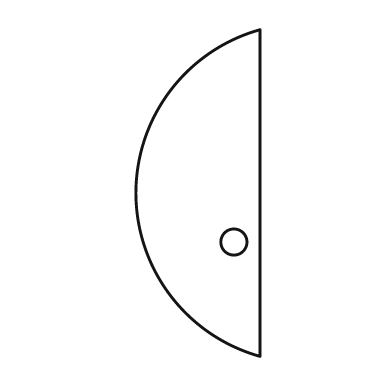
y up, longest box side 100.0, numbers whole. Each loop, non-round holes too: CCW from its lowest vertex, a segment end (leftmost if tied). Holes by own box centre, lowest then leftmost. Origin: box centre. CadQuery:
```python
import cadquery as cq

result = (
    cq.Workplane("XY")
    .moveTo(19.0, -50.0)
    .lineTo(19.0, 50.0)
    .threePointArc((-19.0, 0.0), (19.0, -50.0))
    .close()
    .moveTo(11.0, -15.0)
    .circle(4.0)
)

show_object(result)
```